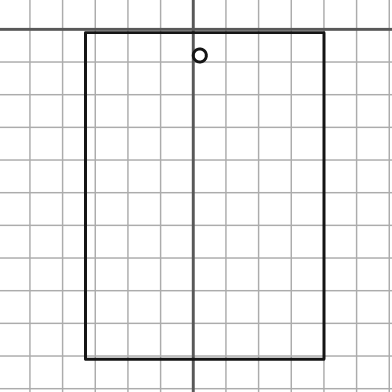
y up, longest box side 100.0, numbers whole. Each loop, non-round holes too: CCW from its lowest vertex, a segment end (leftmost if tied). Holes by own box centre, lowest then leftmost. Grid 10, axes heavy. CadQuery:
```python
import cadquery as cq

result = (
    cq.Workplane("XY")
    .moveTo(-33.0, -101.0)
    .lineTo(40.0, -101.0)
    .lineTo(40.0, -1.0)
    .lineTo(-33.0, -1.0)
    .close()
    .moveTo(2.0, -8.0)
    .circle(2.0)
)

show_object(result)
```